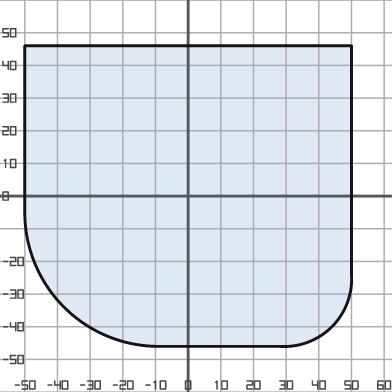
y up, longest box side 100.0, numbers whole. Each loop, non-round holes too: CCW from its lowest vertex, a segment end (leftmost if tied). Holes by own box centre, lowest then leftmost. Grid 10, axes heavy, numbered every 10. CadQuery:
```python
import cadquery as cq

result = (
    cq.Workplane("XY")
    .moveTo(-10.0, -46.0)
    .lineTo(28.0, -46.0)
    .threePointArc((44.0, -40.0), (50.0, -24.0))
    .lineTo(50.0, 46.0)
    .lineTo(-50.0, 46.0)
    .lineTo(-50.0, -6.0)
    .threePointArc((-38.0, -34.0), (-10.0, -46.0))
    .close()
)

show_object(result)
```